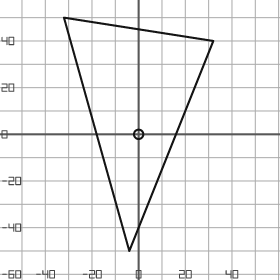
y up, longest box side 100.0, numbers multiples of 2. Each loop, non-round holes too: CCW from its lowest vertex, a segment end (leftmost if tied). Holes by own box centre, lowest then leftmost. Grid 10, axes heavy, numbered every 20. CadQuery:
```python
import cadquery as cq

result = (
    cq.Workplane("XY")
    .moveTo(-4.0, -50.0)
    .lineTo(32.0, 40.0)
    .lineTo(-32.0, 50.0)
    .close()
    .moveTo(0.0, 0.0)
    .circle(2.0)
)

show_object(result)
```